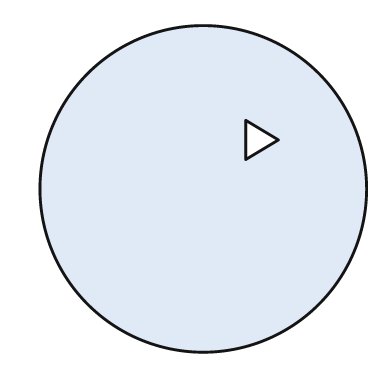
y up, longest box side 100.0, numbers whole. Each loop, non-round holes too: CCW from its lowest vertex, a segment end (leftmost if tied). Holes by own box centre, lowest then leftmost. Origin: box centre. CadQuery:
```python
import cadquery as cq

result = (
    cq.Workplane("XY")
    .moveTo(0.0, 0.0)
    .circle(50.0)
    .moveTo(13.0, 9.0)
    .lineTo(23.0, 15.0)
    .lineTo(13.0, 21.0)
    .close()
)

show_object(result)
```